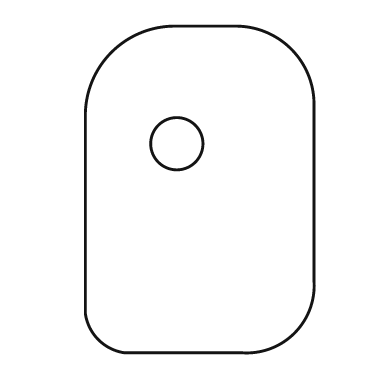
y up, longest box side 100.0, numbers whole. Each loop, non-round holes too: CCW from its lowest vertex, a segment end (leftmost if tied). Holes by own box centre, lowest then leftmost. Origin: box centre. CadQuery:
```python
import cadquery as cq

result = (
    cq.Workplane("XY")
    .moveTo(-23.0, -50.0)
    .lineTo(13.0, -50.0)
    .threePointArc((29.0, -44.0), (35.0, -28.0))
    .lineTo(35.0, 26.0)
    .threePointArc((28.0, 43.0), (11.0, 50.0))
    .lineTo(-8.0, 50.0)
    .threePointArc((-27.0, 42.0), (-35.0, 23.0))
    .lineTo(-35.0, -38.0)
    .threePointArc((-31.0, -46.0), (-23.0, -50.0))
    .close()
    .moveTo(-7.0, 14.0)
    .circle(8.0)
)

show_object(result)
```